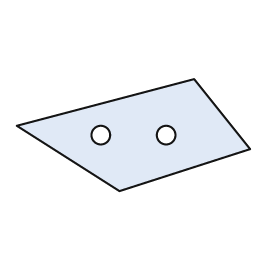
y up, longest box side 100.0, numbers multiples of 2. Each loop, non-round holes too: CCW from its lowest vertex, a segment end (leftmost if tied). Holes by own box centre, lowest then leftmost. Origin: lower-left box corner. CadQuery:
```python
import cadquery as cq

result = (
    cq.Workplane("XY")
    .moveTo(44.0, 0.0)
    .lineTo(100.0, 18.0)
    .lineTo(76.0, 48.0)
    .lineTo(0.0, 28.0)
    .close()
    .moveTo(36.0, 24.0)
    .circle(4.0)
    .moveTo(64.0, 24.0)
    .circle(4.0)
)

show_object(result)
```